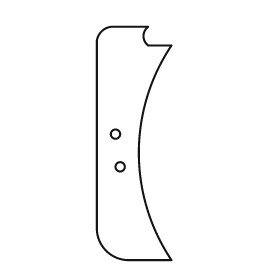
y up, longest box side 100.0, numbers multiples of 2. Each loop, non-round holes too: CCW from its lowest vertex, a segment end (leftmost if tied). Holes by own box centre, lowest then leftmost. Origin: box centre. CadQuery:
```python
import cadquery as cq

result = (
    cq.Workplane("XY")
    .moveTo(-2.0, -50.0)
    .lineTo(16.0, -50.0)
    .threePointArc((2.0, -4.0), (16.0, 42.0))
    .lineTo(6.0, 42.0)
    .threePointArc((4.0, 46.0), (6.0, 50.0))
    .lineTo(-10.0, 50.0)
    .threePointArc((-14.0, 48.0), (-16.0, 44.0))
    .lineTo(-16.0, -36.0)
    .threePointArc((-12.0, -46.0), (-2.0, -50.0))
    .close()
    .moveTo(-6.0, -10.0)
    .circle(2.0)
    .moveTo(-8.0, 4.0)
    .circle(2.0)
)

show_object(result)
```